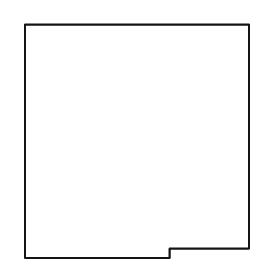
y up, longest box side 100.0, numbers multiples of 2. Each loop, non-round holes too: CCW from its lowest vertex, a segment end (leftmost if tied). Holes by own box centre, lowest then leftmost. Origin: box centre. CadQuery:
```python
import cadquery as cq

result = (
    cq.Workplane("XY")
    .moveTo(-48.0, -50.0)
    .lineTo(14.0, -50.0)
    .lineTo(14.0, -46.0)
    .lineTo(48.0, -46.0)
    .lineTo(48.0, 50.0)
    .lineTo(-48.0, 50.0)
    .close()
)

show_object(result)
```